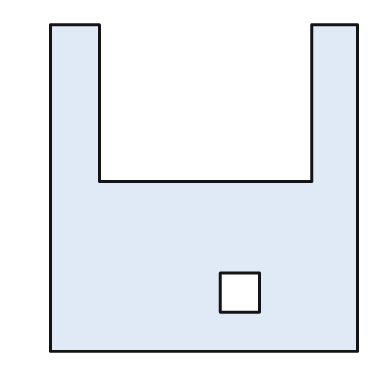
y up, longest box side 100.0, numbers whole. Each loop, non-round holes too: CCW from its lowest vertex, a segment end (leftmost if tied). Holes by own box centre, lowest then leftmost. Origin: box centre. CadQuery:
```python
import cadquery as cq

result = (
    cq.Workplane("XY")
    .moveTo(-47.0, -50.0)
    .lineTo(47.0, -50.0)
    .lineTo(47.0, 50.0)
    .lineTo(33.0, 50.0)
    .lineTo(33.0, 2.0)
    .lineTo(-32.0, 2.0)
    .lineTo(-32.0, 50.0)
    .lineTo(-47.0, 50.0)
    .close()
    .moveTo(5.0, -38.0)
    .lineTo(17.0, -38.0)
    .lineTo(17.0, -26.0)
    .lineTo(5.0, -26.0)
    .close()
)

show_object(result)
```